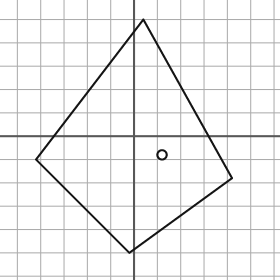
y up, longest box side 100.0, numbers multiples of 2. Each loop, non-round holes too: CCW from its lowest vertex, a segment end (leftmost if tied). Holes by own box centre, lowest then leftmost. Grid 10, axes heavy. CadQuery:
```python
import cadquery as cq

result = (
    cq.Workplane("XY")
    .moveTo(-2.0, -50.0)
    .lineTo(42.0, -18.0)
    .lineTo(4.0, 50.0)
    .lineTo(-42.0, -10.0)
    .close()
    .moveTo(12.0, -8.0)
    .circle(2.0)
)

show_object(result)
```